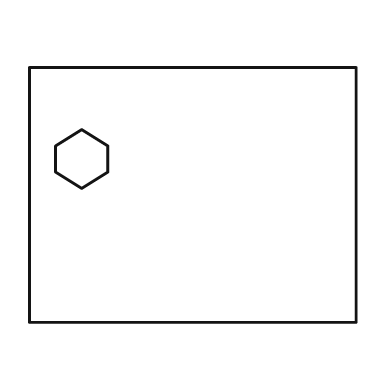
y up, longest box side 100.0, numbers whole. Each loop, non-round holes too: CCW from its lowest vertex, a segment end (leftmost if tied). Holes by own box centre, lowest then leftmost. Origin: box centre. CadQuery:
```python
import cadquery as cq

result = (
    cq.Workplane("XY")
    .moveTo(-50.0, -39.0)
    .lineTo(50.0, -39.0)
    .lineTo(50.0, 39.0)
    .lineTo(-50.0, 39.0)
    .close()
    .moveTo(-34.0, 2.0)
    .lineTo(-26.0, 7.0)
    .lineTo(-26.0, 15.0)
    .lineTo(-34.0, 20.0)
    .lineTo(-42.0, 15.0)
    .lineTo(-42.0, 7.0)
    .close()
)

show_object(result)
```